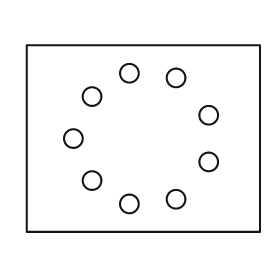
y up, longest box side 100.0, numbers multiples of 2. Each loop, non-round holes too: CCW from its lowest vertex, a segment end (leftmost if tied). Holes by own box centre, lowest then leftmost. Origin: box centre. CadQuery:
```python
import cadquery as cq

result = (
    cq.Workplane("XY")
    .moveTo(-50.0, -40.0)
    .lineTo(50.0, -40.0)
    .lineTo(50.0, 40.0)
    .lineTo(-50.0, 40.0)
    .close()
    .moveTo(-6.0, -28.0)
    .circle(4.0)
    .moveTo(14.0, -26.0)
    .circle(4.0)
    .moveTo(-22.0, -18.0)
    .circle(4.0)
    .moveTo(28.0, -10.0)
    .circle(4.0)
    .moveTo(-30.0, 0.0)
    .circle(4.0)
    .moveTo(28.0, 10.0)
    .circle(4.0)
    .moveTo(-22.0, 18.0)
    .circle(4.0)
    .moveTo(14.0, 26.0)
    .circle(4.0)
    .moveTo(-6.0, 28.0)
    .circle(4.0)
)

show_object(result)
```